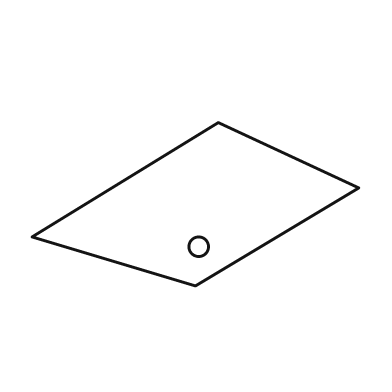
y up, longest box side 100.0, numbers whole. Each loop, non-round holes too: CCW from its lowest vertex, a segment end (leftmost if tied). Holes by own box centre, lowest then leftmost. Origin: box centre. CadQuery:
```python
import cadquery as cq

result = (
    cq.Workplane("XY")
    .moveTo(0.0, -25.0)
    .lineTo(50.0, 5.0)
    .lineTo(7.0, 25.0)
    .lineTo(-50.0, -10.0)
    .close()
    .moveTo(1.0, -13.0)
    .circle(3.0)
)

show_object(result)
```